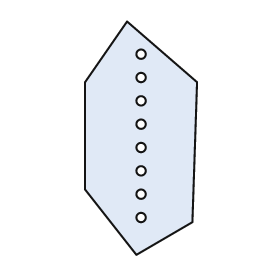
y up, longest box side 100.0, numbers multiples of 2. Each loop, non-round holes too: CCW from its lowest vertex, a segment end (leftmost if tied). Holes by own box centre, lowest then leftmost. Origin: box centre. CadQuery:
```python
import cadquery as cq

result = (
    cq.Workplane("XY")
    .moveTo(-2.0, -50.0)
    .lineTo(22.0, -36.0)
    .lineTo(24.0, 24.0)
    .lineTo(-6.0, 50.0)
    .lineTo(-24.0, 24.0)
    .lineTo(-24.0, -22.0)
    .close()
    .moveTo(0.0, -34.0)
    .circle(2.0)
    .moveTo(0.0, -24.0)
    .circle(2.0)
    .moveTo(0.0, -14.0)
    .circle(2.0)
    .moveTo(0.0, -4.0)
    .circle(2.0)
    .moveTo(0.0, 6.0)
    .circle(2.0)
    .moveTo(0.0, 16.0)
    .circle(2.0)
    .moveTo(0.0, 26.0)
    .circle(2.0)
    .moveTo(0.0, 36.0)
    .circle(2.0)
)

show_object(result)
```